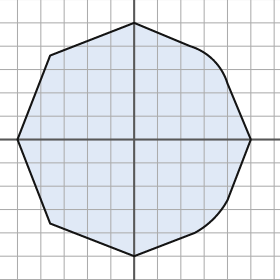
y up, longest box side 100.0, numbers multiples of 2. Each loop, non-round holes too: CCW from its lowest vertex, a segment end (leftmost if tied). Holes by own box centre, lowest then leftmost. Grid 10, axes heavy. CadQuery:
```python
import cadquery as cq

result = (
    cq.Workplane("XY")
    .moveTo(0.0, -50.0)
    .lineTo(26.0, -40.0)
    .threePointArc((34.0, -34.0), (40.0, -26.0))
    .lineTo(50.0, 0.0)
    .lineTo(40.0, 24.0)
    .threePointArc((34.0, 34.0), (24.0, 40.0))
    .lineTo(0.0, 50.0)
    .lineTo(-36.0, 36.0)
    .lineTo(-50.0, 0.0)
    .lineTo(-36.0, -36.0)
    .close()
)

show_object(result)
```